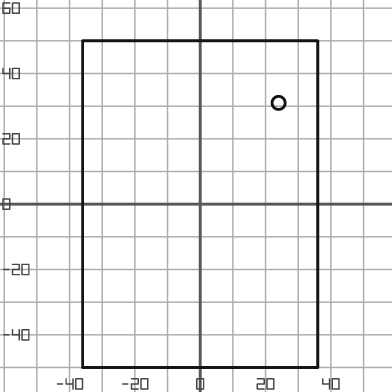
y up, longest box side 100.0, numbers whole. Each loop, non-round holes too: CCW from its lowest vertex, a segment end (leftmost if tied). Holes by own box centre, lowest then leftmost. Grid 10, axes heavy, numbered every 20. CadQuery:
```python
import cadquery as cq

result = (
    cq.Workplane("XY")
    .moveTo(-36.0, -50.0)
    .lineTo(36.0, -50.0)
    .lineTo(36.0, 50.0)
    .lineTo(-36.0, 50.0)
    .close()
    .moveTo(24.0, 31.0)
    .circle(2.0)
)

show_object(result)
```